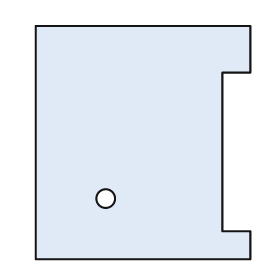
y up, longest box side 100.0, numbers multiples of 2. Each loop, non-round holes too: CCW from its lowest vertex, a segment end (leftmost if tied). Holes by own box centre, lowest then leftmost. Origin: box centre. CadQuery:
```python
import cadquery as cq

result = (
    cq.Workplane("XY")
    .moveTo(-46.0, -50.0)
    .lineTo(46.0, -50.0)
    .lineTo(46.0, -38.0)
    .lineTo(34.0, -38.0)
    .lineTo(34.0, 30.0)
    .lineTo(46.0, 30.0)
    .lineTo(46.0, 50.0)
    .lineTo(-46.0, 50.0)
    .close()
    .moveTo(-16.0, -24.0)
    .circle(4.0)
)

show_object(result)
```